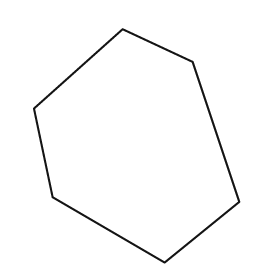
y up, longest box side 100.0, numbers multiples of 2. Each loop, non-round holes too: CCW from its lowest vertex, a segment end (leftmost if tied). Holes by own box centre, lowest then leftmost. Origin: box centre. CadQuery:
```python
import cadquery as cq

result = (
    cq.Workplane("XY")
    .moveTo(12.0, -50.0)
    .lineTo(44.0, -24.0)
    .lineTo(24.0, 36.0)
    .lineTo(-6.0, 50.0)
    .lineTo(-44.0, 16.0)
    .lineTo(-36.0, -22.0)
    .close()
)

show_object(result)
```